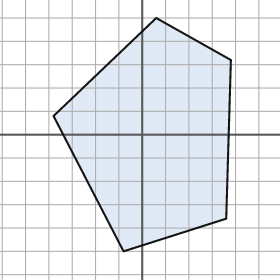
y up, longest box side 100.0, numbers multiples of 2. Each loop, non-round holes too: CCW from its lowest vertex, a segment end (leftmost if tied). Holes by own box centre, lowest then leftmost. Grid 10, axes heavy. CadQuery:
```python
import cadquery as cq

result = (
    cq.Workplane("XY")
    .moveTo(-8.0, -50.0)
    .lineTo(36.0, -36.0)
    .lineTo(38.0, 32.0)
    .lineTo(6.0, 50.0)
    .lineTo(-38.0, 8.0)
    .close()
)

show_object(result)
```